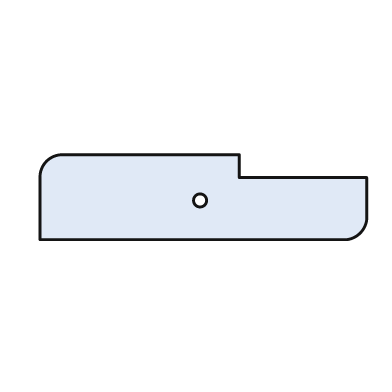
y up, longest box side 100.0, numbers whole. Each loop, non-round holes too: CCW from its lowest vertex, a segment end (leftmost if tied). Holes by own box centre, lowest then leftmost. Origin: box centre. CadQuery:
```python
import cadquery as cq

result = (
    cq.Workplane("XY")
    .moveTo(-50.0, -13.0)
    .lineTo(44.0, -13.0)
    .threePointArc((48.0, -11.0), (50.0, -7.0))
    .lineTo(50.0, 6.0)
    .lineTo(11.0, 6.0)
    .lineTo(11.0, 13.0)
    .lineTo(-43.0, 13.0)
    .threePointArc((-48.0, 11.0), (-50.0, 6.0))
    .close()
    .moveTo(-1.0, -1.0)
    .circle(2.0)
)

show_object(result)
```